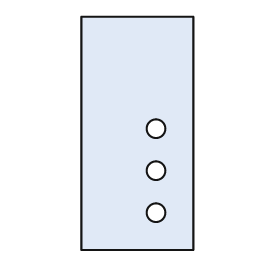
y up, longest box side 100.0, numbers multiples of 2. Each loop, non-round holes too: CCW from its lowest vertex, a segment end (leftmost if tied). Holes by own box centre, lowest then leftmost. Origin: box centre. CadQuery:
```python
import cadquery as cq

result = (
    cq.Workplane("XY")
    .moveTo(-24.0, -50.0)
    .lineTo(24.0, -50.0)
    .lineTo(24.0, 50.0)
    .lineTo(-24.0, 50.0)
    .close()
    .moveTo(8.0, -34.0)
    .circle(4.0)
    .moveTo(8.0, -16.0)
    .circle(4.0)
    .moveTo(8.0, 2.0)
    .circle(4.0)
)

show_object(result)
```